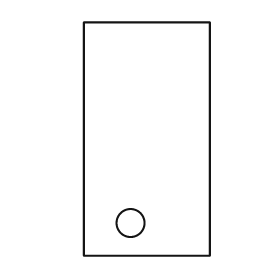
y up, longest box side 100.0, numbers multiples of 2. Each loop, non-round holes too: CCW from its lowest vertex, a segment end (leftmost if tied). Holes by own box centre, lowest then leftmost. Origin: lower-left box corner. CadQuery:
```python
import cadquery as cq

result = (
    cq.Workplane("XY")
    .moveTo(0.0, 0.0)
    .lineTo(54.0, 0.0)
    .lineTo(54.0, 100.0)
    .lineTo(0.0, 100.0)
    .close()
    .moveTo(20.0, 14.0)
    .circle(6.0)
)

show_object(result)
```